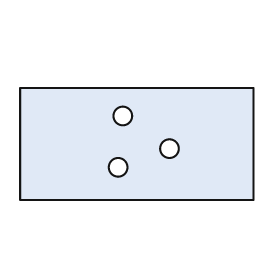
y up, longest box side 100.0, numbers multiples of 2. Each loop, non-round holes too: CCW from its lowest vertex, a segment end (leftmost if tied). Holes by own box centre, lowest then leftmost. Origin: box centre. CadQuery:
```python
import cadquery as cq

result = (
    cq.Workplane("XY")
    .moveTo(-50.0, -24.0)
    .lineTo(50.0, -24.0)
    .lineTo(50.0, 24.0)
    .lineTo(-50.0, 24.0)
    .close()
    .moveTo(-8.0, -10.0)
    .circle(4.0)
    .moveTo(14.0, -2.0)
    .circle(4.0)
    .moveTo(-6.0, 12.0)
    .circle(4.0)
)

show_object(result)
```